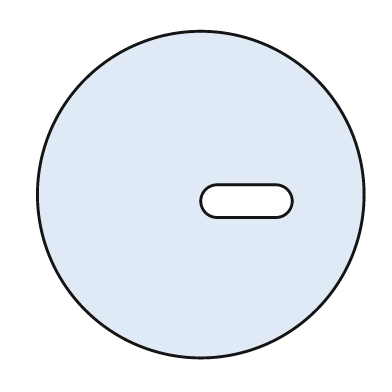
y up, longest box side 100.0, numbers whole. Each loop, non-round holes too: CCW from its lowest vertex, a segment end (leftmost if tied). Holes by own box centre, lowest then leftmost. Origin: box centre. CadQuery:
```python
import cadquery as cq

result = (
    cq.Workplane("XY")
    .moveTo(0.0, 0.0)
    .circle(50.0)
    .moveTo(5.0, -7.0)
    .lineTo(23.0, -7.0)
    .threePointArc((28.0, -2.0), (23.0, 3.0))
    .lineTo(5.0, 3.0)
    .threePointArc((0.0, -2.0), (5.0, -7.0))
    .close()
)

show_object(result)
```